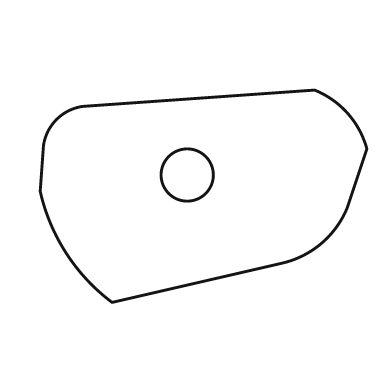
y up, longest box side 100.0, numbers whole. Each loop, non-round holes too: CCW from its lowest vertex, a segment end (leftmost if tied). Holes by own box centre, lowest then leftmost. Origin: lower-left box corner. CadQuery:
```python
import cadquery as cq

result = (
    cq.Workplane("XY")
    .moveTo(22.0, 0.0)
    .lineTo(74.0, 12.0)
    .threePointArc((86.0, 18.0), (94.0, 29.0))
    .lineTo(100.0, 47.0)
    .threePointArc((94.0, 58.0), (84.0, 65.0))
    .lineTo(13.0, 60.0)
    .threePointArc((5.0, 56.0), (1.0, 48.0))
    .lineTo(0.0, 34.0)
    .threePointArc((8.0, 15.0), (22.0, 0.0))
    .close()
    .moveTo(45.0, 39.0)
    .circle(8.0)
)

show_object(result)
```